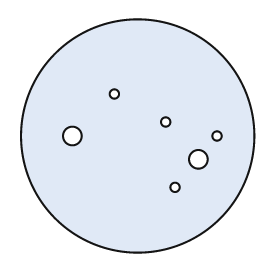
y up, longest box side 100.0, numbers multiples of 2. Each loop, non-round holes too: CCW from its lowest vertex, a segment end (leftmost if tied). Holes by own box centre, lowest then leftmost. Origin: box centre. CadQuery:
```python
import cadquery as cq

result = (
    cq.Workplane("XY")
    .moveTo(0.0, 0.0)
    .circle(50.0)
    .moveTo(16.0, -22.0)
    .circle(2.0)
    .moveTo(26.0, -10.0)
    .circle(4.0)
    .moveTo(-28.0, 0.0)
    .circle(4.0)
    .moveTo(34.0, 0.0)
    .circle(2.0)
    .moveTo(12.0, 6.0)
    .circle(2.0)
    .moveTo(-10.0, 18.0)
    .circle(2.0)
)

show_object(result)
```